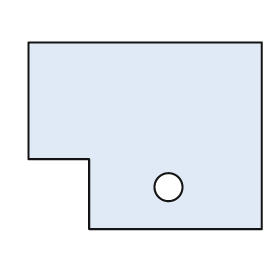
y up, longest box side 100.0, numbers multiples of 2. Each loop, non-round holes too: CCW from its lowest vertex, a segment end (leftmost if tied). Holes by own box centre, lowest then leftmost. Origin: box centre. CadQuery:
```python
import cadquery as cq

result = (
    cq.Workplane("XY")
    .moveTo(-24.0, -40.0)
    .lineTo(50.0, -40.0)
    .lineTo(50.0, 40.0)
    .lineTo(-50.0, 40.0)
    .lineTo(-50.0, -10.0)
    .lineTo(-24.0, -10.0)
    .close()
    .moveTo(10.0, -22.0)
    .circle(6.0)
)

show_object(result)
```